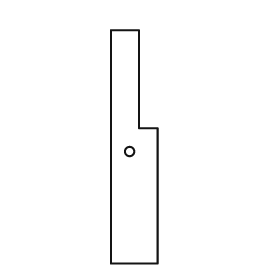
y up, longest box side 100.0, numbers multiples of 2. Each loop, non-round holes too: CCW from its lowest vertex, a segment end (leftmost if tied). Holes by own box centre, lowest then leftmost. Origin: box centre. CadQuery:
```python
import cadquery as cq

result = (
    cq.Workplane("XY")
    .moveTo(-10.0, -50.0)
    .lineTo(10.0, -50.0)
    .lineTo(10.0, 8.0)
    .lineTo(2.0, 8.0)
    .lineTo(2.0, 50.0)
    .lineTo(-10.0, 50.0)
    .close()
    .moveTo(-2.0, -2.0)
    .circle(2.0)
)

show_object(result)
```